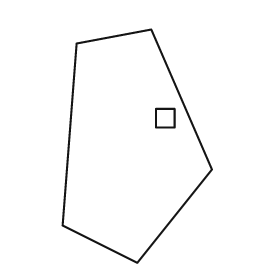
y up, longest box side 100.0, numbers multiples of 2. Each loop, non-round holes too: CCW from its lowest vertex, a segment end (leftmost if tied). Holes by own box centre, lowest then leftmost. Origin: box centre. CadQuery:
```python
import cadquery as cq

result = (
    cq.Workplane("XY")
    .moveTo(0.0, -50.0)
    .lineTo(32.0, -10.0)
    .lineTo(6.0, 50.0)
    .lineTo(-26.0, 44.0)
    .lineTo(-32.0, -34.0)
    .close()
    .moveTo(8.0, 8.0)
    .lineTo(16.0, 8.0)
    .lineTo(16.0, 16.0)
    .lineTo(8.0, 16.0)
    .close()
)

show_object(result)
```